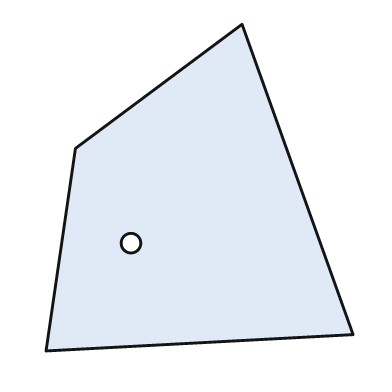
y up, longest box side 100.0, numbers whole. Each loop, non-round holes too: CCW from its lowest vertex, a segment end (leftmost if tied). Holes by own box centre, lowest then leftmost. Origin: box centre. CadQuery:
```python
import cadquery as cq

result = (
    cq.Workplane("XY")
    .moveTo(-47.0, -50.0)
    .lineTo(47.0, -45.0)
    .lineTo(13.0, 50.0)
    .lineTo(-38.0, 12.0)
    .close()
    .moveTo(-21.0, -17.0)
    .circle(3.0)
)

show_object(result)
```